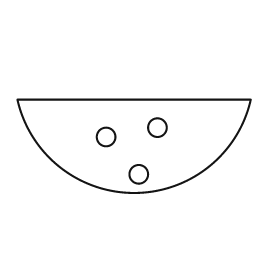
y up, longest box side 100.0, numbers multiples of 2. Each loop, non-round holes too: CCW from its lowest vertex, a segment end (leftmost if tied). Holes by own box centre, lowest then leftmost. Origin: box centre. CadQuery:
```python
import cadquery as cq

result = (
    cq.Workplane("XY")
    .moveTo(-50.0, 20.0)
    .threePointArc((0.0, -20.0), (50.0, 20.0))
    .close()
    .moveTo(2.0, -12.0)
    .circle(4.0)
    .moveTo(-12.0, 4.0)
    .circle(4.0)
    .moveTo(10.0, 8.0)
    .circle(4.0)
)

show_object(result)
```